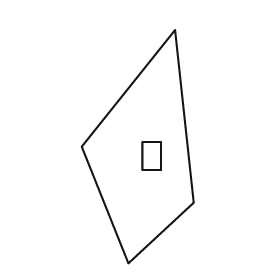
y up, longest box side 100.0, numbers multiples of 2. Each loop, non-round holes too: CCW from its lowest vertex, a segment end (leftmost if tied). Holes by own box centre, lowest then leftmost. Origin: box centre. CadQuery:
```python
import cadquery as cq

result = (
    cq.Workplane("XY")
    .moveTo(-4.0, -50.0)
    .lineTo(24.0, -24.0)
    .lineTo(16.0, 50.0)
    .lineTo(-24.0, 0.0)
    .close()
    .moveTo(2.0, -10.0)
    .lineTo(10.0, -10.0)
    .lineTo(10.0, 2.0)
    .lineTo(2.0, 2.0)
    .close()
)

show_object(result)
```